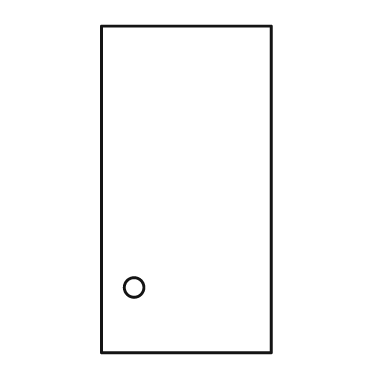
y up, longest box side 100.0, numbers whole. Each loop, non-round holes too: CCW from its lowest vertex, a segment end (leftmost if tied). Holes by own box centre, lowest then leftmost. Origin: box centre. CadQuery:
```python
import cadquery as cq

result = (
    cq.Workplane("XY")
    .moveTo(-26.0, -50.0)
    .lineTo(26.0, -50.0)
    .lineTo(26.0, 50.0)
    .lineTo(-26.0, 50.0)
    .close()
    .moveTo(-16.0, -30.0)
    .circle(3.0)
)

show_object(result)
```